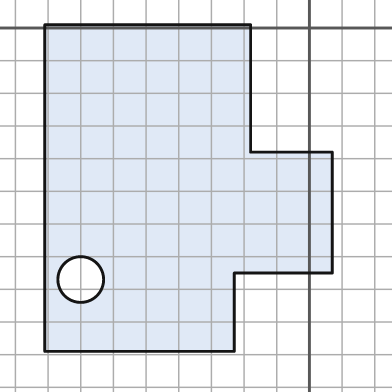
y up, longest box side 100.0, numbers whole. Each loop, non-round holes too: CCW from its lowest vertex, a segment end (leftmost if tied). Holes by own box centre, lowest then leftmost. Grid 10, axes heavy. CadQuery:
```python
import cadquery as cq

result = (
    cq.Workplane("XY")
    .moveTo(-81.0, -99.0)
    .lineTo(-23.0, -99.0)
    .lineTo(-23.0, -75.0)
    .lineTo(7.0, -75.0)
    .lineTo(7.0, -38.0)
    .lineTo(-18.0, -38.0)
    .lineTo(-18.0, 1.0)
    .lineTo(-81.0, 1.0)
    .close()
    .moveTo(-70.0, -77.0)
    .circle(7.0)
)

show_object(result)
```